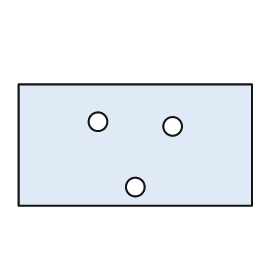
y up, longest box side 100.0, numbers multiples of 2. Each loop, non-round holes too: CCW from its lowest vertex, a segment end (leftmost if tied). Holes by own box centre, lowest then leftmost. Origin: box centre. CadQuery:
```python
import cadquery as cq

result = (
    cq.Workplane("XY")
    .moveTo(-50.0, -26.0)
    .lineTo(50.0, -26.0)
    .lineTo(50.0, 26.0)
    .lineTo(-50.0, 26.0)
    .close()
    .moveTo(0.0, -18.0)
    .circle(4.0)
    .moveTo(16.0, 8.0)
    .circle(4.0)
    .moveTo(-16.0, 10.0)
    .circle(4.0)
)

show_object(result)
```